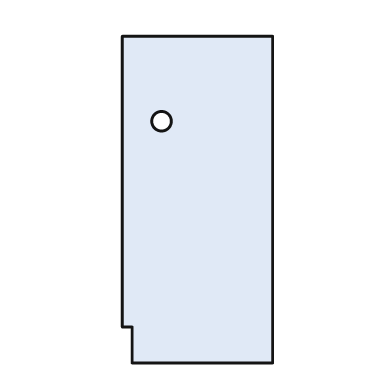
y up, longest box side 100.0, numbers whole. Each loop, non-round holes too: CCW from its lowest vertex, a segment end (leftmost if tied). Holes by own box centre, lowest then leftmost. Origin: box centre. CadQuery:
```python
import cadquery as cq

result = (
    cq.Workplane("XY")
    .moveTo(-20.0, -50.0)
    .lineTo(23.0, -50.0)
    .lineTo(23.0, 50.0)
    .lineTo(-23.0, 50.0)
    .lineTo(-23.0, -39.0)
    .lineTo(-20.0, -39.0)
    .close()
    .moveTo(-11.0, 24.0)
    .circle(3.0)
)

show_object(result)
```